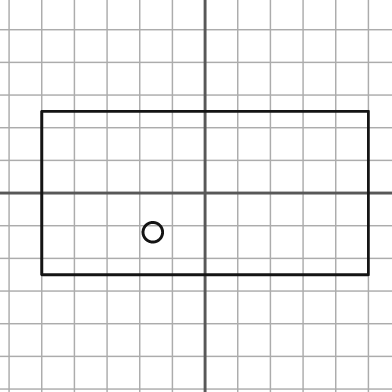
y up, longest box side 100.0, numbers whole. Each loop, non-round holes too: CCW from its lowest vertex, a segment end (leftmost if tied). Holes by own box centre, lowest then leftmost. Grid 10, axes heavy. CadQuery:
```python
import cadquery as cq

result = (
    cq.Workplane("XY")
    .moveTo(-50.0, -25.0)
    .lineTo(50.0, -25.0)
    .lineTo(50.0, 25.0)
    .lineTo(-50.0, 25.0)
    .close()
    .moveTo(-16.0, -12.0)
    .circle(3.0)
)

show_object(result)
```